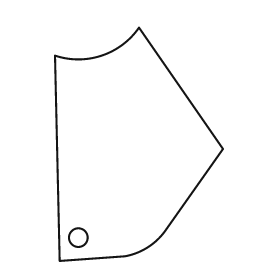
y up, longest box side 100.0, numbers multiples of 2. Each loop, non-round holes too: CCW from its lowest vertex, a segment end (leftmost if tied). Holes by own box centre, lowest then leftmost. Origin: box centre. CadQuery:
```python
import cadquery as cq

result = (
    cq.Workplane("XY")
    .moveTo(-34.0, -50.0)
    .lineTo(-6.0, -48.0)
    .threePointArc((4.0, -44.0), (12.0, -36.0))
    .lineTo(36.0, -2.0)
    .lineTo(0.0, 50.0)
    .threePointArc((-16.0, 38.0), (-36.0, 38.0))
    .close()
    .moveTo(-26.0, -40.0)
    .circle(4.0)
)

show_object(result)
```